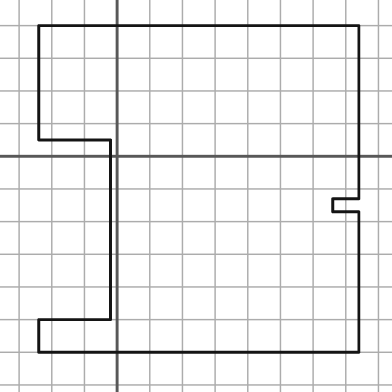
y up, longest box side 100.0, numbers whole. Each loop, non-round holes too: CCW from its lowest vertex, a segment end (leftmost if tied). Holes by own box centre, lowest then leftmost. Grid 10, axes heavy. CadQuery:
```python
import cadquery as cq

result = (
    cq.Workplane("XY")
    .moveTo(-24.0, -60.0)
    .lineTo(74.0, -60.0)
    .lineTo(74.0, -17.0)
    .lineTo(66.0, -17.0)
    .lineTo(66.0, -13.0)
    .lineTo(74.0, -13.0)
    .lineTo(74.0, 40.0)
    .lineTo(-24.0, 40.0)
    .lineTo(-24.0, 5.0)
    .lineTo(-2.0, 5.0)
    .lineTo(-2.0, -50.0)
    .lineTo(-24.0, -50.0)
    .close()
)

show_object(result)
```